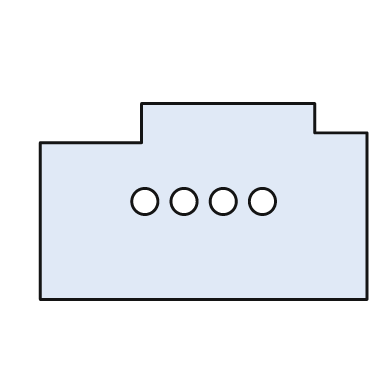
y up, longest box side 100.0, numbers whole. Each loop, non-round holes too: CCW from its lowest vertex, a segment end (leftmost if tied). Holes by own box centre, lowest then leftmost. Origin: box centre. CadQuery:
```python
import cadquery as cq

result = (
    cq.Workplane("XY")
    .moveTo(-50.0, -30.0)
    .lineTo(50.0, -30.0)
    .lineTo(50.0, 21.0)
    .lineTo(34.0, 21.0)
    .lineTo(34.0, 30.0)
    .lineTo(-19.0, 30.0)
    .lineTo(-19.0, 18.0)
    .lineTo(-50.0, 18.0)
    .close()
    .moveTo(-18.0, 0.0)
    .circle(4.0)
    .moveTo(-6.0, 0.0)
    .circle(4.0)
    .moveTo(6.0, 0.0)
    .circle(4.0)
    .moveTo(18.0, 0.0)
    .circle(4.0)
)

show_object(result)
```